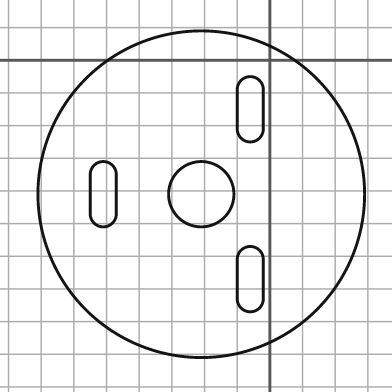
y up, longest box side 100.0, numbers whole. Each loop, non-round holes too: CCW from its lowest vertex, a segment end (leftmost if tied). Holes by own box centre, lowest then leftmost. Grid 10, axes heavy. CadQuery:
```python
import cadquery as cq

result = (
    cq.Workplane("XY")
    .moveTo(-21.0, -41.0)
    .circle(50.0)
    .moveTo(-10.0, -73.0)
    .threePointArc((-6.0, -77.0), (-2.0, -73.0))
    .lineTo(-2.0, -61.0)
    .threePointArc((-6.0, -57.0), (-10.0, -61.0))
    .close()
    .moveTo(-55.0, -47.0)
    .threePointArc((-51.0, -51.0), (-47.0, -47.0))
    .lineTo(-47.0, -35.0)
    .threePointArc((-51.0, -31.0), (-55.0, -35.0))
    .close()
    .moveTo(-21.0, -41.0)
    .circle(10.0)
    .moveTo(-10.0, -21.0)
    .threePointArc((-6.0, -25.0), (-2.0, -21.0))
    .lineTo(-2.0, -9.0)
    .threePointArc((-6.0, -5.0), (-10.0, -9.0))
    .close()
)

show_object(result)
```